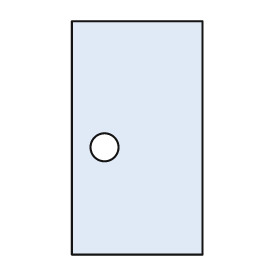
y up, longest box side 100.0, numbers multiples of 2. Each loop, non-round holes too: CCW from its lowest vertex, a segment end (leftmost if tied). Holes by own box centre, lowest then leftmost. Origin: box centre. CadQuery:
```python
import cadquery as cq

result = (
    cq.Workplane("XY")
    .moveTo(-28.0, -50.0)
    .lineTo(28.0, -50.0)
    .lineTo(28.0, 50.0)
    .lineTo(-28.0, 50.0)
    .close()
    .moveTo(-14.0, -4.0)
    .circle(6.0)
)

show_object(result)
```